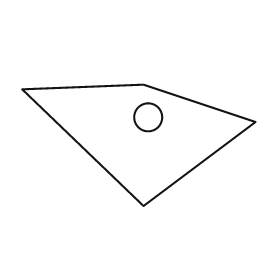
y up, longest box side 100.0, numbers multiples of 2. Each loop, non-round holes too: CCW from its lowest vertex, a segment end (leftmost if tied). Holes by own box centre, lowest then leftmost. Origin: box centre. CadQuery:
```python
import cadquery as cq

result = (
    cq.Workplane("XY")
    .moveTo(2.0, -26.0)
    .lineTo(50.0, 10.0)
    .lineTo(2.0, 26.0)
    .lineTo(-50.0, 24.0)
    .close()
    .moveTo(4.0, 12.0)
    .circle(6.0)
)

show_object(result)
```